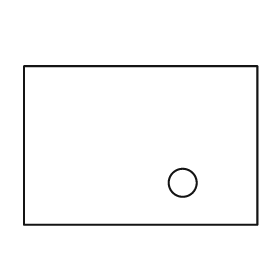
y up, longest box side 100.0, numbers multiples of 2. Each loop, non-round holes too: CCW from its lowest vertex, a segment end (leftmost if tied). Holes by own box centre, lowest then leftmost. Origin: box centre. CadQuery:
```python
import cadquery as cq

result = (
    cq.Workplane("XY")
    .moveTo(-50.0, -34.0)
    .lineTo(50.0, -34.0)
    .lineTo(50.0, 34.0)
    .lineTo(-50.0, 34.0)
    .close()
    .moveTo(18.0, -16.0)
    .circle(6.0)
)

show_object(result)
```